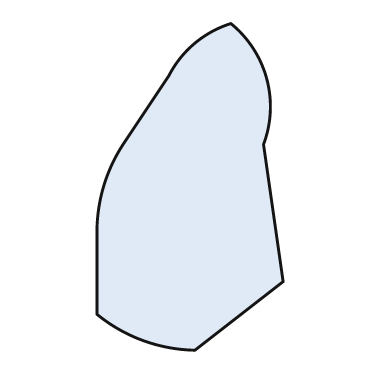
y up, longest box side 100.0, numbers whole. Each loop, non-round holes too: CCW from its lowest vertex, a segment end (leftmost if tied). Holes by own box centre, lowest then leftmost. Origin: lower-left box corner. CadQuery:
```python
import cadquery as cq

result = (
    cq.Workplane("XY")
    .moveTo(30.0, 0.0)
    .lineTo(57.0, 21.0)
    .lineTo(51.0, 63.0)
    .threePointArc((52.0, 83.0), (41.0, 100.0))
    .threePointArc((30.0, 94.0), (22.0, 84.0))
    .lineTo(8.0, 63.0)
    .threePointArc((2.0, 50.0), (0.0, 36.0))
    .lineTo(0.0, 11.0)
    .threePointArc((14.0, 3.0), (30.0, 0.0))
    .close()
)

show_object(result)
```